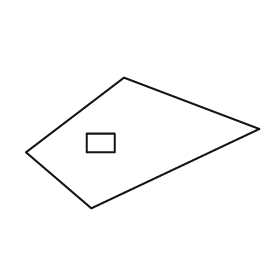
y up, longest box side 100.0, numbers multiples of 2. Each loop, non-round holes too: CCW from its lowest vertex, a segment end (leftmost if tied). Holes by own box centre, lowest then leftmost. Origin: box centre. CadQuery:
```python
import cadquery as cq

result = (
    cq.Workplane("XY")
    .moveTo(-22.0, -28.0)
    .lineTo(50.0, 6.0)
    .lineTo(-8.0, 28.0)
    .lineTo(-50.0, -4.0)
    .close()
    .moveTo(-24.0, -4.0)
    .lineTo(-12.0, -4.0)
    .lineTo(-12.0, 4.0)
    .lineTo(-24.0, 4.0)
    .close()
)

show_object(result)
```